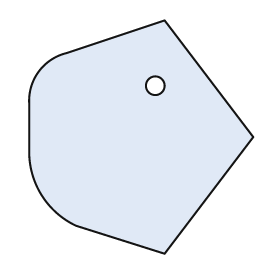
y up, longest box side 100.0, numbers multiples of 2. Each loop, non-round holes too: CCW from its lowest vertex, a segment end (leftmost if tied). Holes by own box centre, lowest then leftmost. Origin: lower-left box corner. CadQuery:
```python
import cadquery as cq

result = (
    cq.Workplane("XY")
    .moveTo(58.0, 0.0)
    .lineTo(96.0, 50.0)
    .lineTo(58.0, 100.0)
    .lineTo(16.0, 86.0)
    .threePointArc((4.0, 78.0), (0.0, 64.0))
    .lineTo(0.0, 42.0)
    .threePointArc((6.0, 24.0), (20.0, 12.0))
    .close()
    .moveTo(54.0, 72.0)
    .circle(4.0)
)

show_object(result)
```